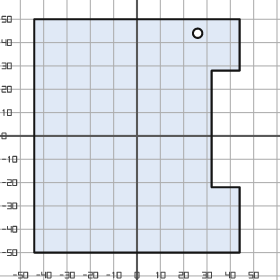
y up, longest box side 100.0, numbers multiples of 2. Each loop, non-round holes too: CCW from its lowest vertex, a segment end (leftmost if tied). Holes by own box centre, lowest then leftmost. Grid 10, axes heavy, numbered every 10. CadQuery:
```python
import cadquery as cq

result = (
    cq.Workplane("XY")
    .moveTo(-44.0, -50.0)
    .lineTo(44.0, -50.0)
    .lineTo(44.0, -22.0)
    .lineTo(32.0, -22.0)
    .lineTo(32.0, 28.0)
    .lineTo(44.0, 28.0)
    .lineTo(44.0, 50.0)
    .lineTo(-44.0, 50.0)
    .close()
    .moveTo(26.0, 44.0)
    .circle(2.0)
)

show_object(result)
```